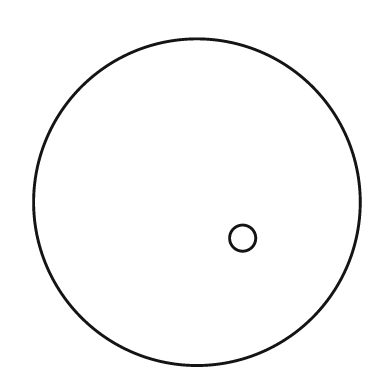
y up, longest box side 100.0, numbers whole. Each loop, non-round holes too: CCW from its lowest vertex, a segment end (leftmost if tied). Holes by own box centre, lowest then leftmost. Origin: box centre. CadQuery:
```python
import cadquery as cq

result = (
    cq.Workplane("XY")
    .moveTo(0.0, 0.0)
    .circle(50.0)
    .moveTo(14.0, -11.0)
    .circle(4.0)
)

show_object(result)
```